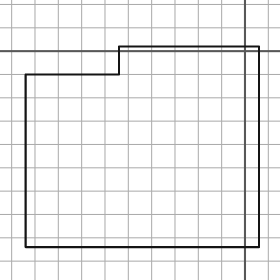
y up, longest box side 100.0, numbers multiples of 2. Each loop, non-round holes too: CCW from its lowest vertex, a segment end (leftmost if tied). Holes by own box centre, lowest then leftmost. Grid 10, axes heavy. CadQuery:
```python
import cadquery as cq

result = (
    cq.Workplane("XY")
    .moveTo(-94.0, -84.0)
    .lineTo(6.0, -84.0)
    .lineTo(6.0, 2.0)
    .lineTo(-54.0, 2.0)
    .lineTo(-54.0, -10.0)
    .lineTo(-94.0, -10.0)
    .close()
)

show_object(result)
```